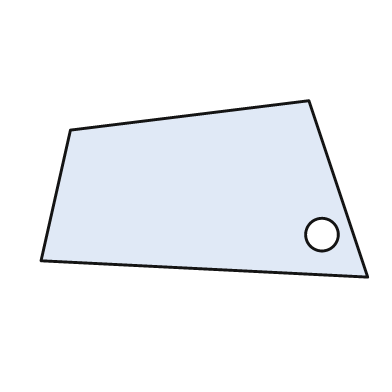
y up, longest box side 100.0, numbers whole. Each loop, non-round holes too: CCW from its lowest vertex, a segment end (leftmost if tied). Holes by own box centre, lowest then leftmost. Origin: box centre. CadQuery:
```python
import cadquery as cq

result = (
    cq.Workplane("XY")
    .moveTo(50.0, -27.0)
    .lineTo(32.0, 27.0)
    .lineTo(-41.0, 18.0)
    .lineTo(-50.0, -22.0)
    .close()
    .moveTo(36.0, -14.0)
    .circle(5.0)
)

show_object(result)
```